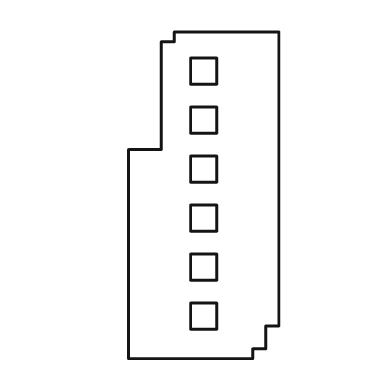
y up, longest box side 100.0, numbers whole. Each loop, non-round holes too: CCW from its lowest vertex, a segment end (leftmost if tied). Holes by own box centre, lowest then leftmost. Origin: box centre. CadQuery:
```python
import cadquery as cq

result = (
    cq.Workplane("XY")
    .moveTo(-23.0, -50.0)
    .lineTo(15.0, -50.0)
    .lineTo(15.0, -47.0)
    .lineTo(19.0, -47.0)
    .lineTo(19.0, -40.0)
    .lineTo(23.0, -40.0)
    .lineTo(23.0, 50.0)
    .lineTo(-9.0, 50.0)
    .lineTo(-9.0, 47.0)
    .lineTo(-13.0, 47.0)
    .lineTo(-13.0, 14.0)
    .lineTo(-23.0, 14.0)
    .close()
    .moveTo(-4.0, -41.0)
    .lineTo(4.0, -41.0)
    .lineTo(4.0, -33.0)
    .lineTo(-4.0, -33.0)
    .close()
    .moveTo(-4.0, -26.0)
    .lineTo(4.0, -26.0)
    .lineTo(4.0, -18.0)
    .lineTo(-4.0, -18.0)
    .close()
    .moveTo(-4.0, -11.0)
    .lineTo(4.0, -11.0)
    .lineTo(4.0, -3.0)
    .lineTo(-4.0, -3.0)
    .close()
    .moveTo(-4.0, 4.0)
    .lineTo(4.0, 4.0)
    .lineTo(4.0, 12.0)
    .lineTo(-4.0, 12.0)
    .close()
    .moveTo(-4.0, 19.0)
    .lineTo(4.0, 19.0)
    .lineTo(4.0, 27.0)
    .lineTo(-4.0, 27.0)
    .close()
    .moveTo(-4.0, 34.0)
    .lineTo(4.0, 34.0)
    .lineTo(4.0, 42.0)
    .lineTo(-4.0, 42.0)
    .close()
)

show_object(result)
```